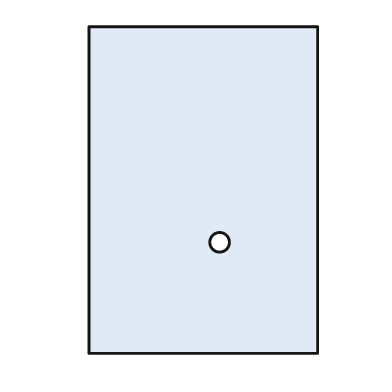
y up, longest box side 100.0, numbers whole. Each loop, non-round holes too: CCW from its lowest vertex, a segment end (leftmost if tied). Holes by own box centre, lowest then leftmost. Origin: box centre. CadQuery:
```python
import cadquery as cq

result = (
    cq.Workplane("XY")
    .moveTo(-35.0, -50.0)
    .lineTo(35.0, -50.0)
    .lineTo(35.0, 50.0)
    .lineTo(-35.0, 50.0)
    .close()
    .moveTo(5.0, -16.0)
    .circle(3.0)
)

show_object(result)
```